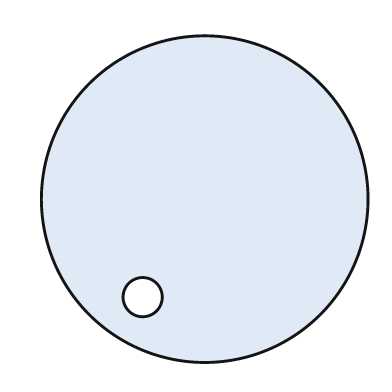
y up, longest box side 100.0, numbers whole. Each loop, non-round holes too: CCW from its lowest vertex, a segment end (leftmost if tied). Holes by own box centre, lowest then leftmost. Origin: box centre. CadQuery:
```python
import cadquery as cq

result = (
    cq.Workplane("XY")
    .moveTo(0.0, 0.0)
    .circle(50.0)
    .moveTo(-19.0, -30.0)
    .circle(6.0)
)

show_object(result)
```